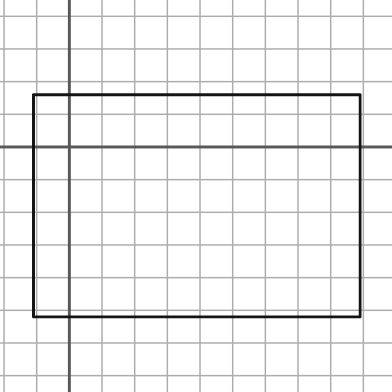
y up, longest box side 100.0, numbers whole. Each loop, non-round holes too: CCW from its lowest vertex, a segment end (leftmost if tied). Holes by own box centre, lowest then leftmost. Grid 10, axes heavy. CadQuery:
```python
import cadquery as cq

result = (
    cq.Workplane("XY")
    .moveTo(-11.0, -52.0)
    .lineTo(89.0, -52.0)
    .lineTo(89.0, 16.0)
    .lineTo(-11.0, 16.0)
    .close()
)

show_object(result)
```